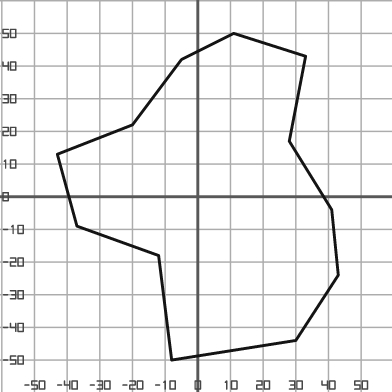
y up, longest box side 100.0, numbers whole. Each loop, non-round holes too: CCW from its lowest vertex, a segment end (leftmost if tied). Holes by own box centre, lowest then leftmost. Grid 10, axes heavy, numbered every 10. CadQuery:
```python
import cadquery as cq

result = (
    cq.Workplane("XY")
    .moveTo(-8.0, -50.0)
    .lineTo(30.0, -44.0)
    .lineTo(43.0, -24.0)
    .lineTo(41.0, -4.0)
    .lineTo(28.0, 17.0)
    .lineTo(33.0, 43.0)
    .lineTo(11.0, 50.0)
    .lineTo(-5.0, 42.0)
    .lineTo(-20.0, 22.0)
    .lineTo(-43.0, 13.0)
    .lineTo(-37.0, -9.0)
    .lineTo(-12.0, -18.0)
    .close()
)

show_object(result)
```